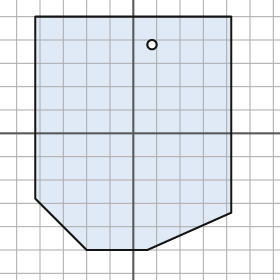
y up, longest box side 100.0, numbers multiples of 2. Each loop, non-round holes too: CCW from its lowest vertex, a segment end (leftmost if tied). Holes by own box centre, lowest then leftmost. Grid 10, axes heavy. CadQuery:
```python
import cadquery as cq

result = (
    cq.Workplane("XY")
    .moveTo(-20.0, -50.0)
    .lineTo(6.0, -50.0)
    .lineTo(42.0, -34.0)
    .lineTo(42.0, 50.0)
    .lineTo(-42.0, 50.0)
    .lineTo(-42.0, -28.0)
    .close()
    .moveTo(8.0, 38.0)
    .circle(2.0)
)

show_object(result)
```